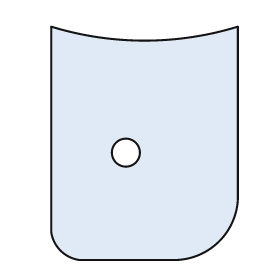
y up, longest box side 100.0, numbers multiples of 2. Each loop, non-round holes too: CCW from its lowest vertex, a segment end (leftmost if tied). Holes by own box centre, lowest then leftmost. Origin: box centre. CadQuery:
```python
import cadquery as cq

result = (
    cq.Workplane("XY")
    .moveTo(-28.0, -50.0)
    .lineTo(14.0, -50.0)
    .threePointArc((32.0, -42.0), (40.0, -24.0))
    .lineTo(40.0, 50.0)
    .threePointArc((0.0, 44.0), (-40.0, 50.0))
    .lineTo(-40.0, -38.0)
    .threePointArc((-36.0, -46.0), (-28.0, -50.0))
    .close()
    .moveTo(-8.0, -4.0)
    .circle(6.0)
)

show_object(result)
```